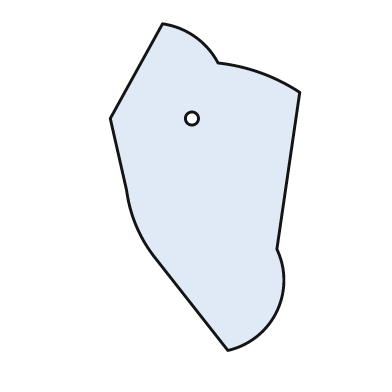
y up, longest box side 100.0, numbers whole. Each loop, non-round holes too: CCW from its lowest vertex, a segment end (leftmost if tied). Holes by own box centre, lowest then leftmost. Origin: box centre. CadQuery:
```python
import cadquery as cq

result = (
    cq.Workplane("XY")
    .moveTo(7.0, -50.0)
    .threePointArc((22.0, -38.0), (22.0, -19.0))
    .lineTo(29.0, 29.0)
    .threePointArc((17.0, 35.0), (4.0, 38.0))
    .threePointArc((-3.0, 46.0), (-13.0, 50.0))
    .lineTo(-29.0, 21.0)
    .lineTo(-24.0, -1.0)
    .threePointArc((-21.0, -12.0), (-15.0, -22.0))
    .close()
    .moveTo(-4.0, 21.0)
    .circle(2.0)
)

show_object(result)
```